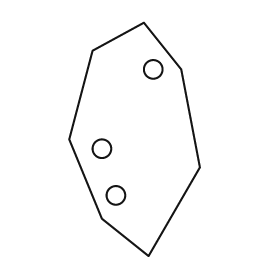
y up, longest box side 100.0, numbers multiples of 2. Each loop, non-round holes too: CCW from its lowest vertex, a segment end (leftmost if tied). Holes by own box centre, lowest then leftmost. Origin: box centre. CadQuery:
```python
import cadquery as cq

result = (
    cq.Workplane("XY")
    .moveTo(6.0, -50.0)
    .lineTo(28.0, -12.0)
    .lineTo(20.0, 30.0)
    .lineTo(4.0, 50.0)
    .lineTo(-18.0, 38.0)
    .lineTo(-28.0, 0.0)
    .lineTo(-14.0, -34.0)
    .close()
    .moveTo(-8.0, -24.0)
    .circle(4.0)
    .moveTo(-14.0, -4.0)
    .circle(4.0)
    .moveTo(8.0, 30.0)
    .circle(4.0)
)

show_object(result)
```